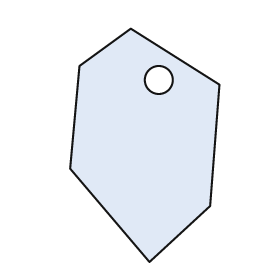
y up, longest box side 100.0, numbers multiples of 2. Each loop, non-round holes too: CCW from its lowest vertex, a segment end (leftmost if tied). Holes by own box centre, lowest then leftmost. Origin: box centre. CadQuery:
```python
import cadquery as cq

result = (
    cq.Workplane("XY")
    .moveTo(2.0, -50.0)
    .lineTo(28.0, -26.0)
    .lineTo(32.0, 26.0)
    .lineTo(-6.0, 50.0)
    .lineTo(-28.0, 34.0)
    .lineTo(-32.0, -10.0)
    .close()
    .moveTo(6.0, 28.0)
    .circle(6.0)
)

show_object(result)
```